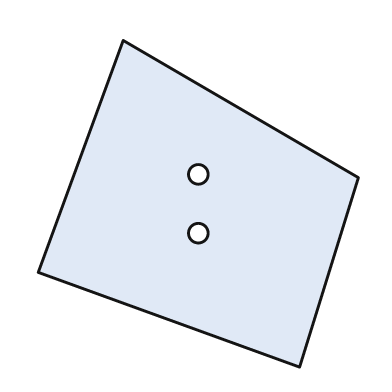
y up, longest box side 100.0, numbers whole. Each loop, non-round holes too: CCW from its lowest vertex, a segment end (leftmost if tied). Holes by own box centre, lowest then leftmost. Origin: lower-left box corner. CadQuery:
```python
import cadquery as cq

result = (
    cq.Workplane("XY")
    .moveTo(80.0, 0.0)
    .lineTo(98.0, 58.0)
    .lineTo(26.0, 100.0)
    .lineTo(0.0, 29.0)
    .close()
    .moveTo(49.0, 41.0)
    .circle(3.0)
    .moveTo(49.0, 59.0)
    .circle(3.0)
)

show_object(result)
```